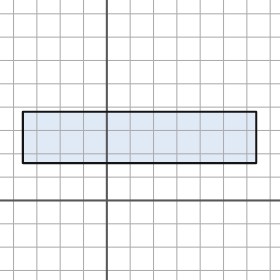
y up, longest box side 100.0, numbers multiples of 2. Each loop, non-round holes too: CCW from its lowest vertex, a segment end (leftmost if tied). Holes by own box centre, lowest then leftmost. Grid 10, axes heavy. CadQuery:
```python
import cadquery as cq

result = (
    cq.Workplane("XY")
    .moveTo(-36.0, 16.0)
    .lineTo(64.0, 16.0)
    .lineTo(64.0, 38.0)
    .lineTo(-36.0, 38.0)
    .close()
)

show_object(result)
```